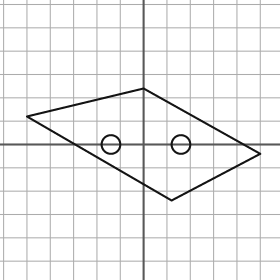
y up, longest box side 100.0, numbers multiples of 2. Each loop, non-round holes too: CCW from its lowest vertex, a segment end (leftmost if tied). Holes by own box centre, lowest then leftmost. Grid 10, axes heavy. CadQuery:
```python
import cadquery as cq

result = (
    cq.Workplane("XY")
    .moveTo(12.0, -24.0)
    .lineTo(50.0, -4.0)
    .lineTo(0.0, 24.0)
    .lineTo(-50.0, 12.0)
    .close()
    .moveTo(-14.0, 0.0)
    .circle(4.0)
    .moveTo(16.0, 0.0)
    .circle(4.0)
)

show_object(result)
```